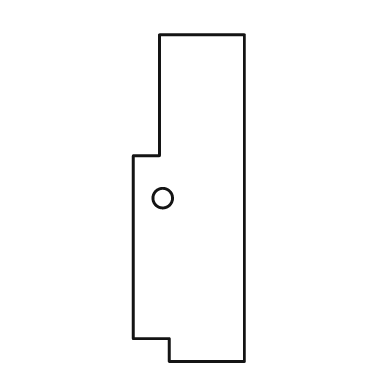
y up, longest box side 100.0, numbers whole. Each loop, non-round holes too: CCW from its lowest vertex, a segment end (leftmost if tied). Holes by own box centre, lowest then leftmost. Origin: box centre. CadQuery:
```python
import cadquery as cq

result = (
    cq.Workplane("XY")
    .moveTo(-6.0, -50.0)
    .lineTo(17.0, -50.0)
    .lineTo(17.0, 50.0)
    .lineTo(-9.0, 50.0)
    .lineTo(-9.0, 13.0)
    .lineTo(-17.0, 13.0)
    .lineTo(-17.0, -43.0)
    .lineTo(-6.0, -43.0)
    .close()
    .moveTo(-8.0, 0.0)
    .circle(3.0)
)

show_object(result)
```